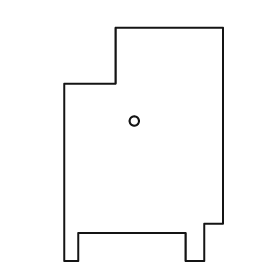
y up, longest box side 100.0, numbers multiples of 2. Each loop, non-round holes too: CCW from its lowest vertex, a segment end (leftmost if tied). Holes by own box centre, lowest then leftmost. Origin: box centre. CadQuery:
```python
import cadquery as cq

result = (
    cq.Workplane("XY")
    .moveTo(-34.0, -50.0)
    .lineTo(-28.0, -50.0)
    .lineTo(-28.0, -38.0)
    .lineTo(18.0, -38.0)
    .lineTo(18.0, -50.0)
    .lineTo(26.0, -50.0)
    .lineTo(26.0, -34.0)
    .lineTo(34.0, -34.0)
    .lineTo(34.0, 50.0)
    .lineTo(-12.0, 50.0)
    .lineTo(-12.0, 26.0)
    .lineTo(-34.0, 26.0)
    .close()
    .moveTo(-4.0, 10.0)
    .circle(2.0)
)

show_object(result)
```